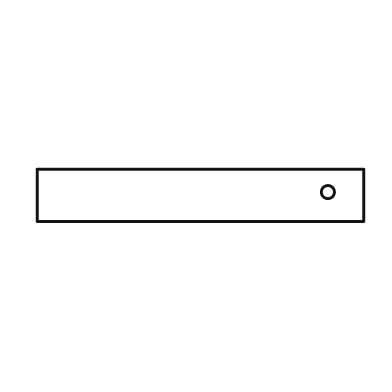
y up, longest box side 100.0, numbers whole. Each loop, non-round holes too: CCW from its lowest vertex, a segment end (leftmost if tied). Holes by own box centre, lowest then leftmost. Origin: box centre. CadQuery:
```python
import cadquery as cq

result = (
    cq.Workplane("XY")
    .moveTo(-50.0, -8.0)
    .lineTo(50.0, -8.0)
    .lineTo(50.0, 8.0)
    .lineTo(-50.0, 8.0)
    .close()
    .moveTo(39.0, 1.0)
    .circle(2.0)
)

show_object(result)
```